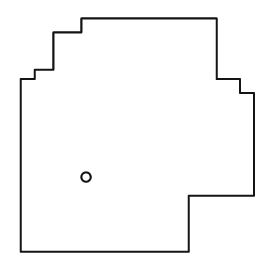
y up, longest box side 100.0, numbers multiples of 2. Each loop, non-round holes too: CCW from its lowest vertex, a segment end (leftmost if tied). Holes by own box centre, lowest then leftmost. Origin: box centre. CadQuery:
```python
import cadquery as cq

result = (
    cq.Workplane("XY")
    .moveTo(-50.0, -50.0)
    .lineTo(22.0, -50.0)
    .lineTo(22.0, -26.0)
    .lineTo(50.0, -26.0)
    .lineTo(50.0, 18.0)
    .lineTo(44.0, 18.0)
    .lineTo(44.0, 24.0)
    .lineTo(34.0, 24.0)
    .lineTo(34.0, 50.0)
    .lineTo(-24.0, 50.0)
    .lineTo(-24.0, 44.0)
    .lineTo(-36.0, 44.0)
    .lineTo(-36.0, 28.0)
    .lineTo(-44.0, 28.0)
    .lineTo(-44.0, 24.0)
    .lineTo(-50.0, 24.0)
    .close()
    .moveTo(-22.0, -18.0)
    .circle(2.0)
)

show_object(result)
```